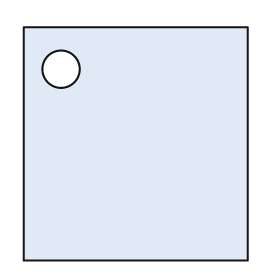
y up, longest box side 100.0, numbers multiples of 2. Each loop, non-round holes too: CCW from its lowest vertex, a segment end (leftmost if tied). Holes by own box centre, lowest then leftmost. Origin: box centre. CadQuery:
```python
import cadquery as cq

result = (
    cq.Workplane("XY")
    .moveTo(-48.0, -50.0)
    .lineTo(48.0, -50.0)
    .lineTo(48.0, 50.0)
    .lineTo(-48.0, 50.0)
    .close()
    .moveTo(-32.0, 32.0)
    .circle(8.0)
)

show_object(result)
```